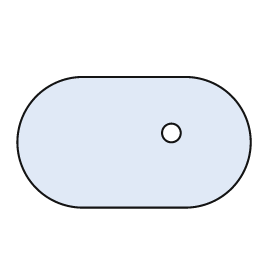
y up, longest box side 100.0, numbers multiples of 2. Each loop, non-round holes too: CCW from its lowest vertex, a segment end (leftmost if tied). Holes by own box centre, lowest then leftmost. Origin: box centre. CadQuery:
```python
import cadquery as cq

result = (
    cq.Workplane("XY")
    .moveTo(-22.0, -28.0)
    .lineTo(22.0, -28.0)
    .threePointArc((50.0, 0.0), (22.0, 28.0))
    .lineTo(-22.0, 28.0)
    .threePointArc((-50.0, 0.0), (-22.0, -28.0))
    .close()
    .moveTo(16.0, 4.0)
    .circle(4.0)
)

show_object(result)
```